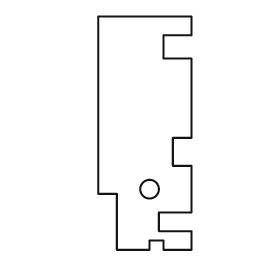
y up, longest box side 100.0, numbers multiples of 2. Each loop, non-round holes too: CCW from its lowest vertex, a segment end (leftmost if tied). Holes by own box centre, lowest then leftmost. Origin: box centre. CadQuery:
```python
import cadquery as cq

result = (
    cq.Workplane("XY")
    .moveTo(-12.0, -50.0)
    .lineTo(2.0, -50.0)
    .lineTo(2.0, -46.0)
    .lineTo(8.0, -46.0)
    .lineTo(8.0, -50.0)
    .lineTo(20.0, -50.0)
    .lineTo(20.0, -42.0)
    .lineTo(6.0, -42.0)
    .lineTo(6.0, -34.0)
    .lineTo(20.0, -34.0)
    .lineTo(20.0, -14.0)
    .lineTo(12.0, -14.0)
    .lineTo(12.0, -2.0)
    .lineTo(20.0, -2.0)
    .lineTo(20.0, 32.0)
    .lineTo(8.0, 32.0)
    .lineTo(8.0, 42.0)
    .lineTo(20.0, 42.0)
    .lineTo(20.0, 50.0)
    .lineTo(-20.0, 50.0)
    .lineTo(-20.0, -26.0)
    .lineTo(-12.0, -26.0)
    .close()
    .moveTo(2.0, -24.0)
    .circle(4.0)
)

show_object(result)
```